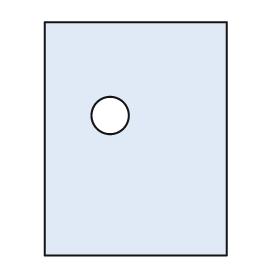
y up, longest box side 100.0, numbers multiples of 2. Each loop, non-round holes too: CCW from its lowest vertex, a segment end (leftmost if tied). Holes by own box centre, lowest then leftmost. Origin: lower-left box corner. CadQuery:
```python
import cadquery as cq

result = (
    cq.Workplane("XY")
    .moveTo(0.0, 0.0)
    .lineTo(78.0, 0.0)
    .lineTo(78.0, 100.0)
    .lineTo(0.0, 100.0)
    .close()
    .moveTo(28.0, 60.0)
    .circle(8.0)
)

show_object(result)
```